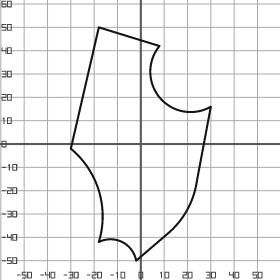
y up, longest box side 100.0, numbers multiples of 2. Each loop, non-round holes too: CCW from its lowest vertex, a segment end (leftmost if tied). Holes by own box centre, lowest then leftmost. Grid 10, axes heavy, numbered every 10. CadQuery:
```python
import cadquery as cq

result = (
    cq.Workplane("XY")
    .moveTo(-2.0, -50.0)
    .lineTo(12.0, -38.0)
    .threePointArc((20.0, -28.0), (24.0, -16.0))
    .lineTo(30.0, 16.0)
    .threePointArc((8.0, 20.0), (8.0, 42.0))
    .lineTo(-18.0, 50.0)
    .lineTo(-30.0, -2.0)
    .threePointArc((-18.0, -20.0), (-18.0, -42.0))
    .threePointArc((-8.0, -42.0), (-2.0, -50.0))
    .close()
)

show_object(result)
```